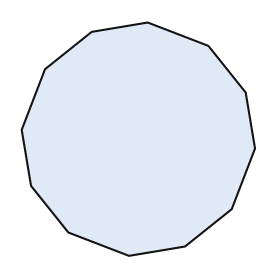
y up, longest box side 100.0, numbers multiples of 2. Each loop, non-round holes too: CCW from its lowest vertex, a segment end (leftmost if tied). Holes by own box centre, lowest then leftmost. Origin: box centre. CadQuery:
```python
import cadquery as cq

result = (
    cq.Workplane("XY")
    .moveTo(-4.0, -50.0)
    .lineTo(20.0, -46.0)
    .lineTo(40.0, -30.0)
    .lineTo(50.0, -4.0)
    .lineTo(46.0, 20.0)
    .lineTo(30.0, 40.0)
    .lineTo(4.0, 50.0)
    .lineTo(-20.0, 46.0)
    .lineTo(-40.0, 30.0)
    .lineTo(-50.0, 4.0)
    .lineTo(-46.0, -20.0)
    .lineTo(-30.0, -40.0)
    .close()
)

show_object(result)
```